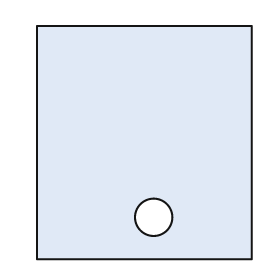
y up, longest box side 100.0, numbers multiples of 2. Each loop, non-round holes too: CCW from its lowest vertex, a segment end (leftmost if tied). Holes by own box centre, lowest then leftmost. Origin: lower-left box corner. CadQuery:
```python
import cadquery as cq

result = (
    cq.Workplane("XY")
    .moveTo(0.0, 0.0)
    .lineTo(92.0, 0.0)
    .lineTo(92.0, 100.0)
    .lineTo(0.0, 100.0)
    .close()
    .moveTo(50.0, 18.0)
    .circle(8.0)
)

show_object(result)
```